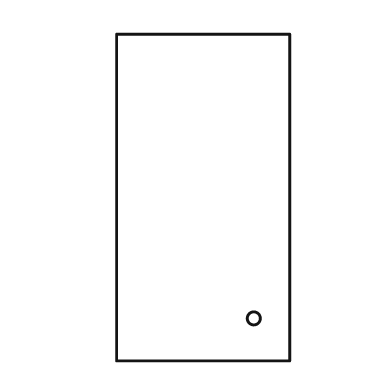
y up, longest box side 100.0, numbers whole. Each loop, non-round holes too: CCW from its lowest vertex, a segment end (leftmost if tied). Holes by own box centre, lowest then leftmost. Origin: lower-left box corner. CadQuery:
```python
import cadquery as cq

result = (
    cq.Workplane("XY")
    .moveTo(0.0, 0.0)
    .lineTo(53.0, 0.0)
    .lineTo(53.0, 100.0)
    .lineTo(0.0, 100.0)
    .close()
    .moveTo(42.0, 13.0)
    .circle(2.0)
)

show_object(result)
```